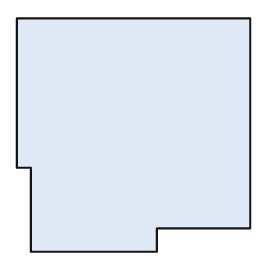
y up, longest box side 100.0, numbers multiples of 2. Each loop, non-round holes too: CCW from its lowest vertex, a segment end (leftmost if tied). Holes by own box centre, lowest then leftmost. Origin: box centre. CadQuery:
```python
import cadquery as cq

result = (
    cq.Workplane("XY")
    .moveTo(-44.0, -50.0)
    .lineTo(10.0, -50.0)
    .lineTo(10.0, -40.0)
    .lineTo(50.0, -40.0)
    .lineTo(50.0, 50.0)
    .lineTo(-50.0, 50.0)
    .lineTo(-50.0, -14.0)
    .lineTo(-44.0, -14.0)
    .close()
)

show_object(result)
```